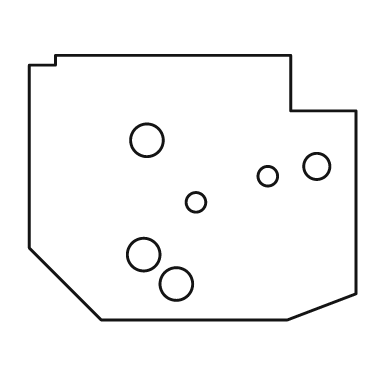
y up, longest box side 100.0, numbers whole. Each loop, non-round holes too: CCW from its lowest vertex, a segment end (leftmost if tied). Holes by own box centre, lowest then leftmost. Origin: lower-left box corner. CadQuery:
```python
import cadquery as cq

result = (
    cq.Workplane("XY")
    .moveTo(22.0, 0.0)
    .lineTo(79.0, 0.0)
    .lineTo(100.0, 8.0)
    .lineTo(100.0, 64.0)
    .lineTo(80.0, 64.0)
    .lineTo(80.0, 81.0)
    .lineTo(8.0, 81.0)
    .lineTo(8.0, 78.0)
    .lineTo(0.0, 78.0)
    .lineTo(0.0, 22.0)
    .close()
    .moveTo(45.0, 11.0)
    .circle(5.0)
    .moveTo(35.0, 20.0)
    .circle(5.0)
    .moveTo(51.0, 36.0)
    .circle(3.0)
    .moveTo(73.0, 44.0)
    .circle(3.0)
    .moveTo(88.0, 47.0)
    .circle(4.0)
    .moveTo(36.0, 55.0)
    .circle(5.0)
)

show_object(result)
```